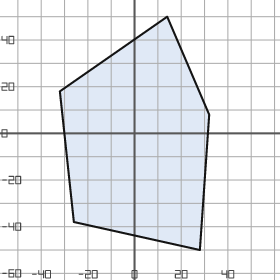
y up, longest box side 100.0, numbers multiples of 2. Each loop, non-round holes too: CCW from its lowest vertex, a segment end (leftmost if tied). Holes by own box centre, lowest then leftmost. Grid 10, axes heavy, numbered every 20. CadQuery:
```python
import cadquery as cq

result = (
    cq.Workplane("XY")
    .moveTo(28.0, -50.0)
    .lineTo(32.0, 8.0)
    .lineTo(14.0, 50.0)
    .lineTo(-32.0, 18.0)
    .lineTo(-26.0, -38.0)
    .close()
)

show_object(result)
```